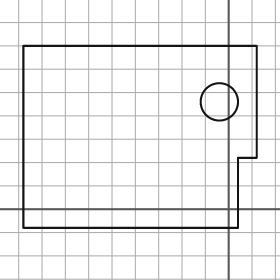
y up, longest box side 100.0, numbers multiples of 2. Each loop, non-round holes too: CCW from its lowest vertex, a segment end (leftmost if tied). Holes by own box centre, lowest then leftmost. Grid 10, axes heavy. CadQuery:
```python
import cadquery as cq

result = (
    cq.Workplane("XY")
    .moveTo(-88.0, -8.0)
    .lineTo(4.0, -8.0)
    .lineTo(4.0, 22.0)
    .lineTo(12.0, 22.0)
    .lineTo(12.0, 70.0)
    .lineTo(-88.0, 70.0)
    .close()
    .moveTo(-4.0, 46.0)
    .circle(8.0)
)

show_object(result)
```